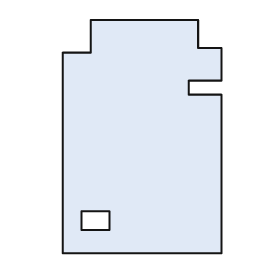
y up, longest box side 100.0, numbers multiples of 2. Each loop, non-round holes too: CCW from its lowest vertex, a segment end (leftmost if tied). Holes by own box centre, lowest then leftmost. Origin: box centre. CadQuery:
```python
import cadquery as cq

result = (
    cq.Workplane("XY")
    .moveTo(-34.0, -50.0)
    .lineTo(34.0, -50.0)
    .lineTo(34.0, 18.0)
    .lineTo(20.0, 18.0)
    .lineTo(20.0, 24.0)
    .lineTo(34.0, 24.0)
    .lineTo(34.0, 38.0)
    .lineTo(24.0, 38.0)
    .lineTo(24.0, 50.0)
    .lineTo(-22.0, 50.0)
    .lineTo(-22.0, 36.0)
    .lineTo(-34.0, 36.0)
    .close()
    .moveTo(-26.0, -40.0)
    .lineTo(-14.0, -40.0)
    .lineTo(-14.0, -32.0)
    .lineTo(-26.0, -32.0)
    .close()
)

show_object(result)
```